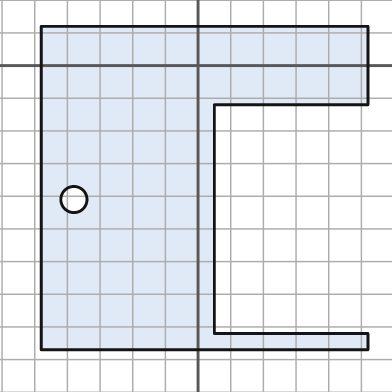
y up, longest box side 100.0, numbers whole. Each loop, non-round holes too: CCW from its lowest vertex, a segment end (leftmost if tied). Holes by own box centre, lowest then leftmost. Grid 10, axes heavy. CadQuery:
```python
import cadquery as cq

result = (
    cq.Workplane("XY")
    .moveTo(-48.0, -87.0)
    .lineTo(52.0, -87.0)
    .lineTo(52.0, -82.0)
    .lineTo(5.0, -82.0)
    .lineTo(5.0, -12.0)
    .lineTo(52.0, -12.0)
    .lineTo(52.0, 12.0)
    .lineTo(-48.0, 12.0)
    .close()
    .moveTo(-38.0, -41.0)
    .circle(4.0)
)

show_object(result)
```